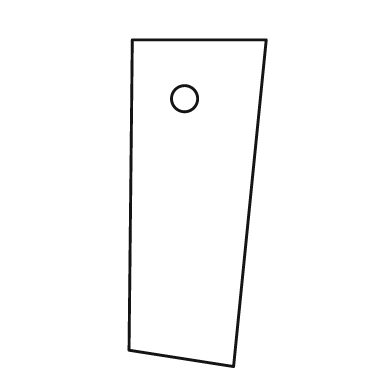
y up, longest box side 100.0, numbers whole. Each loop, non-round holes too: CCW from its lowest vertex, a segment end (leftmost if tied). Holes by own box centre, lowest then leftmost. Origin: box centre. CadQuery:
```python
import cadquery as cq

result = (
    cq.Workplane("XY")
    .moveTo(11.0, -50.0)
    .lineTo(21.0, 50.0)
    .lineTo(-20.0, 50.0)
    .lineTo(-21.0, -45.0)
    .close()
    .moveTo(-4.0, 32.0)
    .circle(4.0)
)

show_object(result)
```